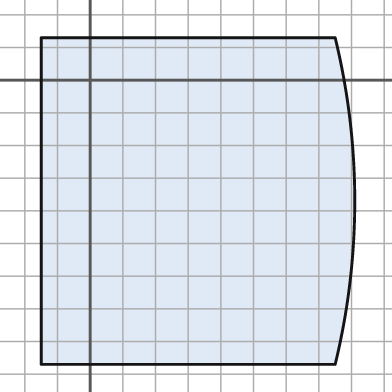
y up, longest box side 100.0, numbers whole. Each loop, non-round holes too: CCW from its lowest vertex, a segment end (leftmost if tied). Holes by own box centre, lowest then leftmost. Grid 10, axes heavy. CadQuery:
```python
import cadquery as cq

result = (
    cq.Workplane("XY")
    .moveTo(-15.0, -87.0)
    .lineTo(75.0, -87.0)
    .threePointArc((81.0, -37.0), (75.0, 13.0))
    .lineTo(-15.0, 13.0)
    .close()
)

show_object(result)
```